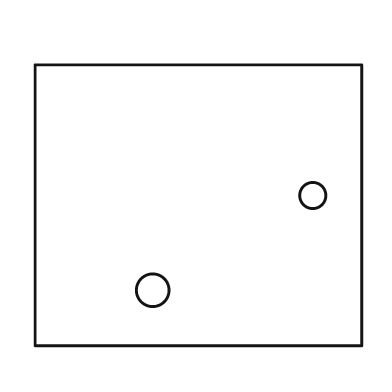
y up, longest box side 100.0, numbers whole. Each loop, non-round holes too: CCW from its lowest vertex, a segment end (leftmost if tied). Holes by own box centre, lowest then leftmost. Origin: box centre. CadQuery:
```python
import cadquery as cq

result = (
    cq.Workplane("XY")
    .moveTo(-50.0, -43.0)
    .lineTo(50.0, -43.0)
    .lineTo(50.0, 43.0)
    .lineTo(-50.0, 43.0)
    .close()
    .moveTo(-14.0, -26.0)
    .circle(5.0)
    .moveTo(35.0, 3.0)
    .circle(4.0)
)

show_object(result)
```